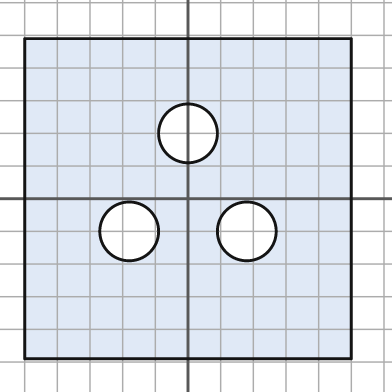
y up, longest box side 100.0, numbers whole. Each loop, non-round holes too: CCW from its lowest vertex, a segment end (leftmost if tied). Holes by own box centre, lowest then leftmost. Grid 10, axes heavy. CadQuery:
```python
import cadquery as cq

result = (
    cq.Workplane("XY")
    .moveTo(-50.0, -49.0)
    .lineTo(50.0, -49.0)
    .lineTo(50.0, 49.0)
    .lineTo(-50.0, 49.0)
    .close()
    .moveTo(-18.0, -10.0)
    .circle(9.0)
    .moveTo(18.0, -10.0)
    .circle(9.0)
    .moveTo(0.0, 20.0)
    .circle(9.0)
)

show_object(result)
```